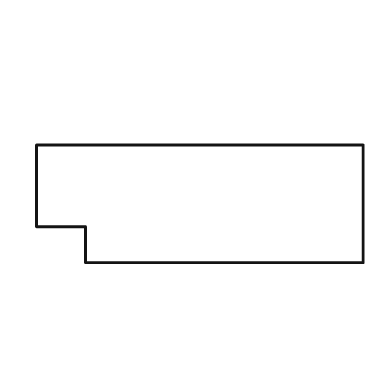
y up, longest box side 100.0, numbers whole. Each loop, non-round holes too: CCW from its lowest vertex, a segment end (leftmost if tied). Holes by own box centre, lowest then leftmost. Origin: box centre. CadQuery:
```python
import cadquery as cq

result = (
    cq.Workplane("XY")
    .moveTo(-35.0, -18.0)
    .lineTo(50.0, -18.0)
    .lineTo(50.0, 18.0)
    .lineTo(-50.0, 18.0)
    .lineTo(-50.0, -7.0)
    .lineTo(-35.0, -7.0)
    .close()
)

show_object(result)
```